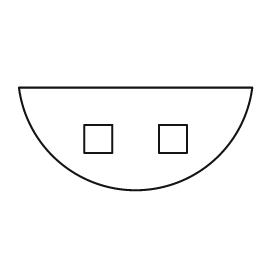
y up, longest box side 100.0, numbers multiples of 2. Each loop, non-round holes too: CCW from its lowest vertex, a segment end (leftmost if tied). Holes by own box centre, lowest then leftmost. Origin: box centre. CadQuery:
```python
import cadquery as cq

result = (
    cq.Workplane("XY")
    .moveTo(-50.0, 22.0)
    .threePointArc((0.0, -22.0), (50.0, 22.0))
    .close()
    .moveTo(-22.0, -6.0)
    .lineTo(-10.0, -6.0)
    .lineTo(-10.0, 6.0)
    .lineTo(-22.0, 6.0)
    .close()
    .moveTo(10.0, -6.0)
    .lineTo(22.0, -6.0)
    .lineTo(22.0, 6.0)
    .lineTo(10.0, 6.0)
    .close()
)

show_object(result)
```